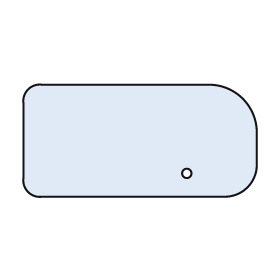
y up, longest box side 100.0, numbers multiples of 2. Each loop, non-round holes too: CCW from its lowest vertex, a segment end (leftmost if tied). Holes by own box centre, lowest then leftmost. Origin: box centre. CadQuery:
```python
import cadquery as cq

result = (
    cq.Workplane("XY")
    .moveTo(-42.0, -24.0)
    .lineTo(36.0, -24.0)
    .threePointArc((46.0, -20.0), (50.0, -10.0))
    .lineTo(50.0, 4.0)
    .threePointArc((44.0, 18.0), (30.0, 24.0))
    .lineTo(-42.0, 24.0)
    .threePointArc((-48.0, 22.0), (-50.0, 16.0))
    .lineTo(-50.0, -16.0)
    .threePointArc((-48.0, -22.0), (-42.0, -24.0))
    .close()
    .moveTo(20.0, -14.0)
    .circle(2.0)
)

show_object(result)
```